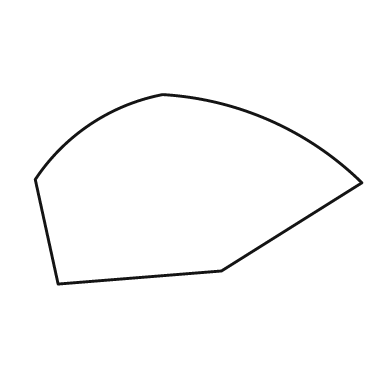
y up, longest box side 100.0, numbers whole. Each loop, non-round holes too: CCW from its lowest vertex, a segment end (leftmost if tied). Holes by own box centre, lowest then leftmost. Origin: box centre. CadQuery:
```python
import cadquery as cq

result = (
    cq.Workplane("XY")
    .moveTo(-43.0, -29.0)
    .lineTo(7.0, -25.0)
    .lineTo(50.0, 2.0)
    .threePointArc((22.0, 21.0), (-11.0, 29.0))
    .threePointArc((-33.0, 20.0), (-50.0, 3.0))
    .close()
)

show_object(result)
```